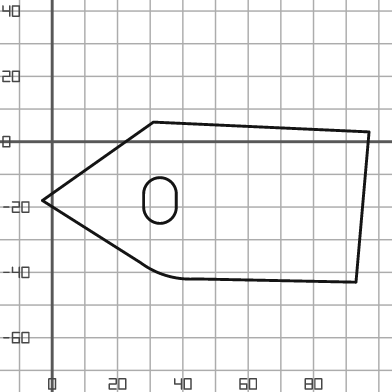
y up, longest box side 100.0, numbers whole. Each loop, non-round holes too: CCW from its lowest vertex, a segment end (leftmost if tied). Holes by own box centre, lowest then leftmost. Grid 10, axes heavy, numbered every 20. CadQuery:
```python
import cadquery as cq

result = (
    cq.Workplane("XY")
    .moveTo(93.0, -43.0)
    .lineTo(97.0, 3.0)
    .lineTo(31.0, 6.0)
    .lineTo(-3.0, -18.0)
    .lineTo(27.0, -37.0)
    .threePointArc((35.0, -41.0), (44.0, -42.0))
    .close()
    .moveTo(28.0, -20.0)
    .threePointArc((33.0, -25.0), (38.0, -20.0))
    .lineTo(38.0, -16.0)
    .threePointArc((33.0, -11.0), (28.0, -16.0))
    .close()
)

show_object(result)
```